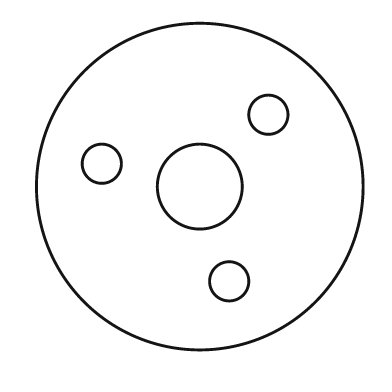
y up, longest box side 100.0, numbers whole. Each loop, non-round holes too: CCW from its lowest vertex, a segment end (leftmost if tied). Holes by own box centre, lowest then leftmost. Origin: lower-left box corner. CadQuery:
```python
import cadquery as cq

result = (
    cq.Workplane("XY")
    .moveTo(50.0, 50.0)
    .circle(50.0)
    .moveTo(59.0, 21.0)
    .circle(6.0)
    .moveTo(50.0, 50.0)
    .circle(13.0)
    .moveTo(20.0, 57.0)
    .circle(6.0)
    .moveTo(71.0, 72.0)
    .circle(6.0)
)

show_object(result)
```